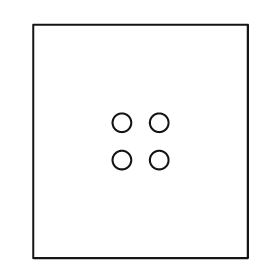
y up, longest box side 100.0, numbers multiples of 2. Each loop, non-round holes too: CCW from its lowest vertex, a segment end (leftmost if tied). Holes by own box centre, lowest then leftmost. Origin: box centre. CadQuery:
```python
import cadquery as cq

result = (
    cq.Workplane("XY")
    .moveTo(-46.0, -50.0)
    .lineTo(46.0, -50.0)
    .lineTo(46.0, 50.0)
    .lineTo(-46.0, 50.0)
    .close()
    .moveTo(-8.0, -8.0)
    .circle(4.0)
    .moveTo(8.0, -8.0)
    .circle(4.0)
    .moveTo(-8.0, 8.0)
    .circle(4.0)
    .moveTo(8.0, 8.0)
    .circle(4.0)
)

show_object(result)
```